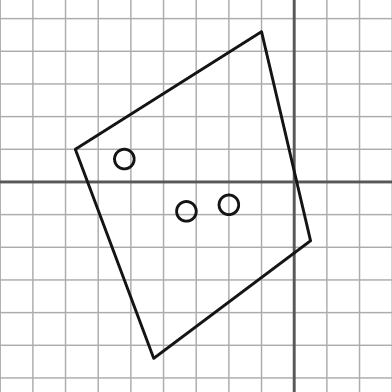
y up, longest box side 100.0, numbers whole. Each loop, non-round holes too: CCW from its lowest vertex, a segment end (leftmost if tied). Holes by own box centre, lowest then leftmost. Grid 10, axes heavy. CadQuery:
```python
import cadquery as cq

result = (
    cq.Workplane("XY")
    .moveTo(-43.0, -54.0)
    .lineTo(5.0, -18.0)
    .lineTo(-10.0, 46.0)
    .lineTo(-67.0, 10.0)
    .close()
    .moveTo(-33.0, -9.0)
    .circle(3.0)
    .moveTo(-20.0, -7.0)
    .circle(3.0)
    .moveTo(-52.0, 7.0)
    .circle(3.0)
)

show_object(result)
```